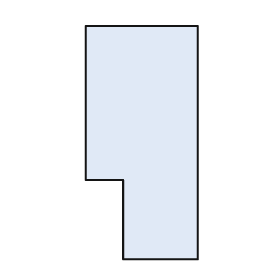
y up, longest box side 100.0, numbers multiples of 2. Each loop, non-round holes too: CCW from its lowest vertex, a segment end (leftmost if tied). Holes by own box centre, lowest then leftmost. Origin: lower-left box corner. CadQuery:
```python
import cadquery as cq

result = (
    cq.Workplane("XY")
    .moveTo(16.0, 0.0)
    .lineTo(48.0, 0.0)
    .lineTo(48.0, 100.0)
    .lineTo(0.0, 100.0)
    .lineTo(0.0, 34.0)
    .lineTo(16.0, 34.0)
    .close()
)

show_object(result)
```